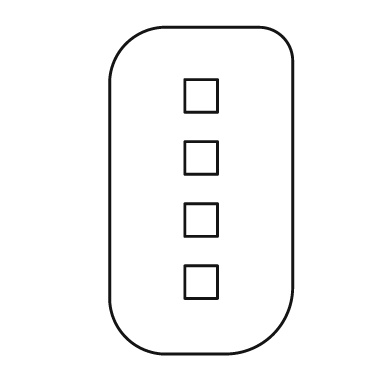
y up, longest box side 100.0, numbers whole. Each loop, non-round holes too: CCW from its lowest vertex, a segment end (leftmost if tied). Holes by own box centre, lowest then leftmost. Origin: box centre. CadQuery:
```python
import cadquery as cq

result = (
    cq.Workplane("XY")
    .moveTo(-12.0, -50.0)
    .lineTo(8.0, -50.0)
    .threePointArc((22.0, -44.0), (28.0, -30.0))
    .lineTo(28.0, 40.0)
    .threePointArc((25.0, 47.0), (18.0, 50.0))
    .lineTo(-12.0, 50.0)
    .threePointArc((-23.0, 45.0), (-28.0, 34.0))
    .lineTo(-28.0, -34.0)
    .threePointArc((-23.0, -45.0), (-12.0, -50.0))
    .close()
    .moveTo(-5.0, -33.0)
    .lineTo(5.0, -33.0)
    .lineTo(5.0, -23.0)
    .lineTo(-5.0, -23.0)
    .close()
    .moveTo(-5.0, -14.0)
    .lineTo(5.0, -14.0)
    .lineTo(5.0, -4.0)
    .lineTo(-5.0, -4.0)
    .close()
    .moveTo(-5.0, 5.0)
    .lineTo(5.0, 5.0)
    .lineTo(5.0, 15.0)
    .lineTo(-5.0, 15.0)
    .close()
    .moveTo(-5.0, 24.0)
    .lineTo(5.0, 24.0)
    .lineTo(5.0, 34.0)
    .lineTo(-5.0, 34.0)
    .close()
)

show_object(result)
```